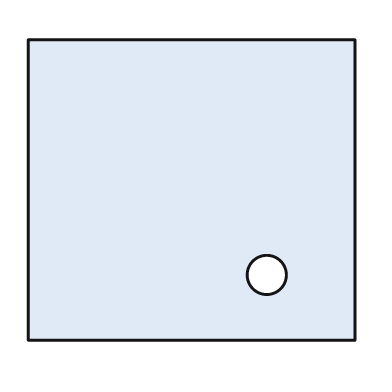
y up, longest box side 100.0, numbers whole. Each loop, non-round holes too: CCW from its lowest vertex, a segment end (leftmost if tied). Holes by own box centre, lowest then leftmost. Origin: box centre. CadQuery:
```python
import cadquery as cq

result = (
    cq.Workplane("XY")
    .moveTo(-50.0, -46.0)
    .lineTo(50.0, -46.0)
    .lineTo(50.0, 46.0)
    .lineTo(-50.0, 46.0)
    .close()
    .moveTo(23.0, -26.0)
    .circle(6.0)
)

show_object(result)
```